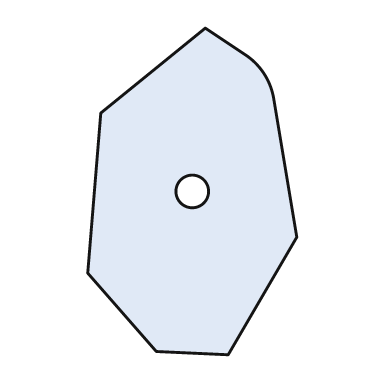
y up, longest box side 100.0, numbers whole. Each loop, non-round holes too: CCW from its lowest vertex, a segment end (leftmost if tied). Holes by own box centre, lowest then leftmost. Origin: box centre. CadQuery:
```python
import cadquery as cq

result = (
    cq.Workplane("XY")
    .moveTo(11.0, -50.0)
    .lineTo(32.0, -14.0)
    .lineTo(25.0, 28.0)
    .threePointArc((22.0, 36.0), (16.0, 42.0))
    .lineTo(4.0, 50.0)
    .lineTo(-28.0, 24.0)
    .lineTo(-32.0, -25.0)
    .lineTo(-11.0, -49.0)
    .close()
    .moveTo(0.0, 0.0)
    .circle(5.0)
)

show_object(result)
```